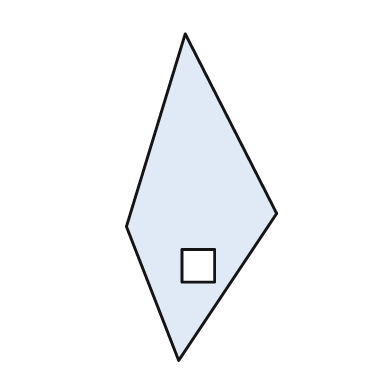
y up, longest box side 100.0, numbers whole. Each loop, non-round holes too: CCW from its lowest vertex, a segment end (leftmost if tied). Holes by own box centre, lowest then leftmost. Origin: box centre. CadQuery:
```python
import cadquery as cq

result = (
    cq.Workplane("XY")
    .moveTo(-7.0, -50.0)
    .lineTo(23.0, -5.0)
    .lineTo(-5.0, 50.0)
    .lineTo(-23.0, -9.0)
    .close()
    .moveTo(-6.0, -26.0)
    .lineTo(4.0, -26.0)
    .lineTo(4.0, -16.0)
    .lineTo(-6.0, -16.0)
    .close()
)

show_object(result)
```